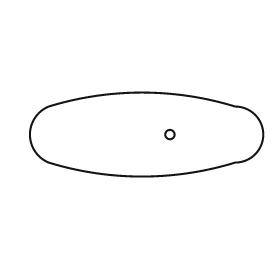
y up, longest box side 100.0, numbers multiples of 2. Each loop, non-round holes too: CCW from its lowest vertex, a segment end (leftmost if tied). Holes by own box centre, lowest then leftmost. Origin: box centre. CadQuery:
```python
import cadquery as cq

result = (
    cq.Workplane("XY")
    .moveTo(-42.0, -12.0)
    .threePointArc((-2.0, -18.0), (38.0, -12.0))
    .threePointArc((50.0, 0.0), (38.0, 12.0))
    .threePointArc((-2.0, 18.0), (-42.0, 12.0))
    .threePointArc((-50.0, 0.0), (-42.0, -12.0))
    .close()
    .moveTo(10.0, 0.0)
    .circle(2.0)
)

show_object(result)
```